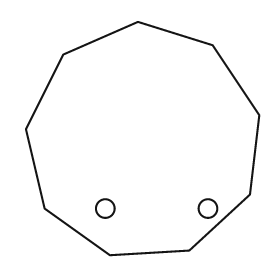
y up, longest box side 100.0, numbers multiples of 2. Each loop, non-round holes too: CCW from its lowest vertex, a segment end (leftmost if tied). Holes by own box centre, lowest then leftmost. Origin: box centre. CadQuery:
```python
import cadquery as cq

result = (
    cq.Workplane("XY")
    .moveTo(-14.0, -50.0)
    .lineTo(20.0, -48.0)
    .lineTo(46.0, -24.0)
    .lineTo(50.0, 10.0)
    .lineTo(30.0, 40.0)
    .lineTo(-2.0, 50.0)
    .lineTo(-34.0, 36.0)
    .lineTo(-50.0, 4.0)
    .lineTo(-42.0, -30.0)
    .close()
    .moveTo(-16.0, -30.0)
    .circle(4.0)
    .moveTo(28.0, -30.0)
    .circle(4.0)
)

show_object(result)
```